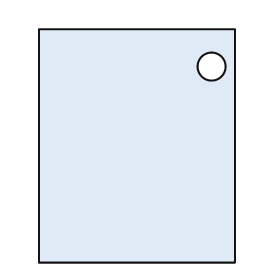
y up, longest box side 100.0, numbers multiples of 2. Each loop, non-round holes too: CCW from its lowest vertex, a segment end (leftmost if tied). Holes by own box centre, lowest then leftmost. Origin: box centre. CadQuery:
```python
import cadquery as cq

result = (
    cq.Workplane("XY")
    .moveTo(-42.0, -50.0)
    .lineTo(42.0, -50.0)
    .lineTo(42.0, 50.0)
    .lineTo(-42.0, 50.0)
    .close()
    .moveTo(32.0, 34.0)
    .circle(6.0)
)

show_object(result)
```